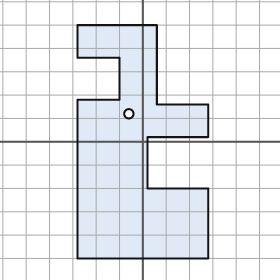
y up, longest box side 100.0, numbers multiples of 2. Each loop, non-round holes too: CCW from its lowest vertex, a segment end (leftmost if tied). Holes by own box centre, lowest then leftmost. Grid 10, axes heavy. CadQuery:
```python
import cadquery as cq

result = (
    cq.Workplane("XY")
    .moveTo(-28.0, -50.0)
    .lineTo(28.0, -50.0)
    .lineTo(28.0, -20.0)
    .lineTo(2.0, -20.0)
    .lineTo(2.0, 2.0)
    .lineTo(28.0, 2.0)
    .lineTo(28.0, 16.0)
    .lineTo(6.0, 16.0)
    .lineTo(6.0, 50.0)
    .lineTo(-28.0, 50.0)
    .lineTo(-28.0, 36.0)
    .lineTo(-10.0, 36.0)
    .lineTo(-10.0, 18.0)
    .lineTo(-28.0, 18.0)
    .close()
    .moveTo(-6.0, 12.0)
    .circle(2.0)
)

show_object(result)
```